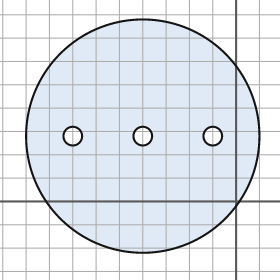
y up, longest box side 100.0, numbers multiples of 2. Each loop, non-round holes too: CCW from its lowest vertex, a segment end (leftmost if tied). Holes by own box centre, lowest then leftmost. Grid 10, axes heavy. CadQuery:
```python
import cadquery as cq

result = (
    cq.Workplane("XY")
    .moveTo(-40.0, 28.0)
    .circle(50.0)
    .moveTo(-70.0, 28.0)
    .circle(4.0)
    .moveTo(-40.0, 28.0)
    .circle(4.0)
    .moveTo(-10.0, 28.0)
    .circle(4.0)
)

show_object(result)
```